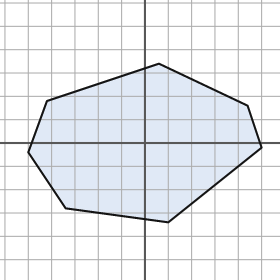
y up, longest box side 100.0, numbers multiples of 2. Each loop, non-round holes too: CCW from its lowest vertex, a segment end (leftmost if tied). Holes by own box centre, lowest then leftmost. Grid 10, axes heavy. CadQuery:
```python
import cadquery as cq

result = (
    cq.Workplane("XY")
    .moveTo(10.0, -34.0)
    .lineTo(50.0, -2.0)
    .lineTo(44.0, 16.0)
    .lineTo(6.0, 34.0)
    .lineTo(-42.0, 18.0)
    .lineTo(-50.0, -4.0)
    .lineTo(-34.0, -28.0)
    .close()
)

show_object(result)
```